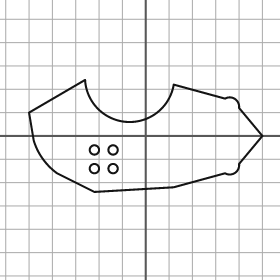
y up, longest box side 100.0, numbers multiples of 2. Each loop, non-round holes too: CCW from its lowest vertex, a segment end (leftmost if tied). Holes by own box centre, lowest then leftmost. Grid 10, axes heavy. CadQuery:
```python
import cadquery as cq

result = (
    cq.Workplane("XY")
    .moveTo(-22.0, -24.0)
    .lineTo(12.0, -22.0)
    .lineTo(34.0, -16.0)
    .threePointArc((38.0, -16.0), (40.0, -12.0))
    .lineTo(50.0, 0.0)
    .lineTo(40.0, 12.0)
    .threePointArc((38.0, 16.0), (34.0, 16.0))
    .lineTo(12.0, 22.0)
    .threePointArc((-8.0, 6.0), (-26.0, 24.0))
    .lineTo(-50.0, 10.0)
    .lineTo(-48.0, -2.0)
    .threePointArc((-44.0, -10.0), (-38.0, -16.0))
    .close()
    .moveTo(-22.0, -14.0)
    .circle(2.0)
    .moveTo(-14.0, -14.0)
    .circle(2.0)
    .moveTo(-22.0, -6.0)
    .circle(2.0)
    .moveTo(-14.0, -6.0)
    .circle(2.0)
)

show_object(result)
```